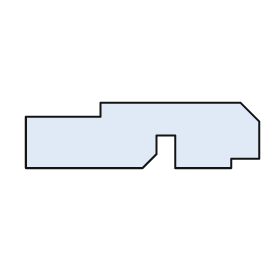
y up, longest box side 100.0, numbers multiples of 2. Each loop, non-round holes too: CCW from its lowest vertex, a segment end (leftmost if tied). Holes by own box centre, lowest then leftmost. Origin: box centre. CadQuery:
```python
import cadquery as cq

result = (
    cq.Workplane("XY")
    .moveTo(-50.0, -14.0)
    .lineTo(0.0, -14.0)
    .lineTo(6.0, -8.0)
    .lineTo(6.0, 0.0)
    .lineTo(14.0, 0.0)
    .lineTo(14.0, -14.0)
    .lineTo(38.0, -14.0)
    .lineTo(38.0, -10.0)
    .lineTo(50.0, -10.0)
    .lineTo(50.0, 6.0)
    .lineTo(42.0, 14.0)
    .lineTo(-18.0, 14.0)
    .lineTo(-18.0, 8.0)
    .lineTo(-50.0, 8.0)
    .close()
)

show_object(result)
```